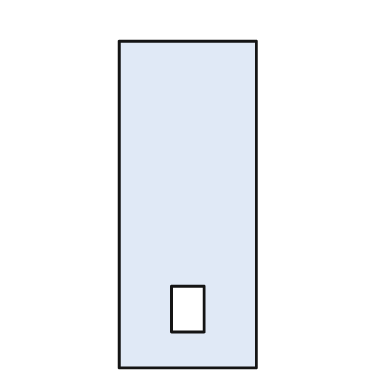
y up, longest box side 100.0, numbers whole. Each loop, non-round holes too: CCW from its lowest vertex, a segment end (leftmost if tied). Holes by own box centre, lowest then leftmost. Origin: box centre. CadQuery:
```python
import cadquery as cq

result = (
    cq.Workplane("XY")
    .moveTo(-21.0, -50.0)
    .lineTo(21.0, -50.0)
    .lineTo(21.0, 50.0)
    .lineTo(-21.0, 50.0)
    .close()
    .moveTo(-5.0, -39.0)
    .lineTo(5.0, -39.0)
    .lineTo(5.0, -25.0)
    .lineTo(-5.0, -25.0)
    .close()
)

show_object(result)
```